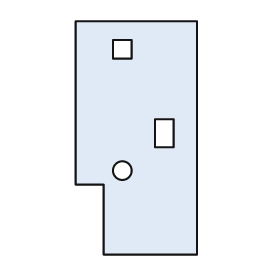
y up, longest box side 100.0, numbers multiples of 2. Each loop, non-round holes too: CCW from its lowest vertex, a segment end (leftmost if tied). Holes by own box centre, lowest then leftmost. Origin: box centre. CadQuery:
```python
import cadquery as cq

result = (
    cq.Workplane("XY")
    .moveTo(-14.0, -50.0)
    .lineTo(26.0, -50.0)
    .lineTo(26.0, 50.0)
    .lineTo(-26.0, 50.0)
    .lineTo(-26.0, -20.0)
    .lineTo(-14.0, -20.0)
    .close()
    .moveTo(-6.0, -14.0)
    .circle(4.0)
    .moveTo(8.0, -4.0)
    .lineTo(16.0, -4.0)
    .lineTo(16.0, 8.0)
    .lineTo(8.0, 8.0)
    .close()
    .moveTo(-10.0, 34.0)
    .lineTo(-2.0, 34.0)
    .lineTo(-2.0, 42.0)
    .lineTo(-10.0, 42.0)
    .close()
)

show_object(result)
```